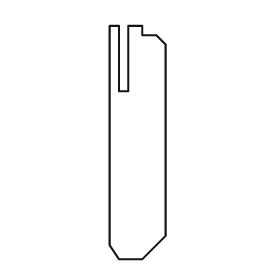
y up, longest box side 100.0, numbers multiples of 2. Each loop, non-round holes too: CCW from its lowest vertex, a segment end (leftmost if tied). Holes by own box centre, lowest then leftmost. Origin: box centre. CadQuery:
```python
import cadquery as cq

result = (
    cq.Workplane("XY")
    .moveTo(-8.0, -50.0)
    .lineTo(2.0, -50.0)
    .lineTo(12.0, -40.0)
    .lineTo(12.0, 42.0)
    .lineTo(8.0, 46.0)
    .lineTo(2.0, 46.0)
    .lineTo(2.0, 50.0)
    .lineTo(-4.0, 50.0)
    .lineTo(-4.0, 22.0)
    .lineTo(-8.0, 22.0)
    .lineTo(-8.0, 50.0)
    .lineTo(-12.0, 50.0)
    .lineTo(-12.0, -44.0)
    .close()
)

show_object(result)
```